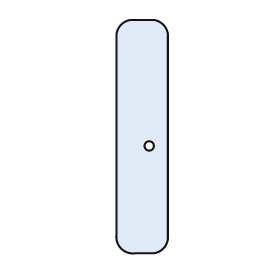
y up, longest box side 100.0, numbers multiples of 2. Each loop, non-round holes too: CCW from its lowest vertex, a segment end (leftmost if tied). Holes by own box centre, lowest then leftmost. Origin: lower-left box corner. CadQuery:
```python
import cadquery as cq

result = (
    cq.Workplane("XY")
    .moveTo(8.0, 0.0)
    .lineTo(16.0, 0.0)
    .threePointArc((20.0, 2.0), (22.0, 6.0))
    .lineTo(22.0, 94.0)
    .threePointArc((20.0, 98.0), (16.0, 100.0))
    .lineTo(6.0, 100.0)
    .threePointArc((2.0, 98.0), (0.0, 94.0))
    .lineTo(0.0, 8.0)
    .threePointArc((2.0, 2.0), (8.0, 0.0))
    .close()
    .moveTo(14.0, 46.0)
    .circle(2.0)
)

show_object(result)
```